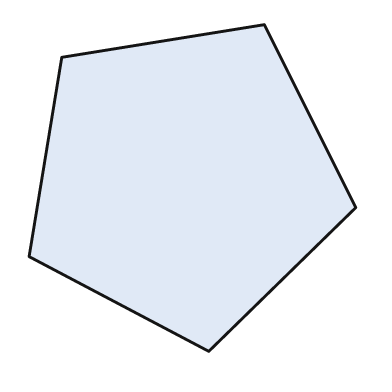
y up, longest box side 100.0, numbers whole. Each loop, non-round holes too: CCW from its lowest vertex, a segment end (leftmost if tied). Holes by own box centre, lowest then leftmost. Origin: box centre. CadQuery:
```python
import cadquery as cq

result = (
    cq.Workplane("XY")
    .moveTo(5.0, -50.0)
    .lineTo(50.0, -6.0)
    .lineTo(22.0, 50.0)
    .lineTo(-40.0, 40.0)
    .lineTo(-50.0, -21.0)
    .close()
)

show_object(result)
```